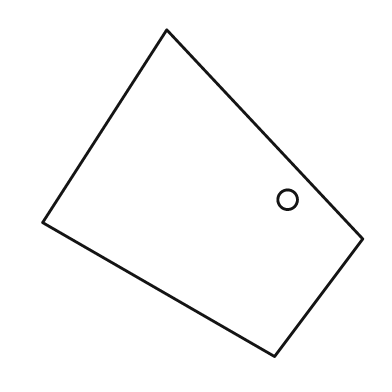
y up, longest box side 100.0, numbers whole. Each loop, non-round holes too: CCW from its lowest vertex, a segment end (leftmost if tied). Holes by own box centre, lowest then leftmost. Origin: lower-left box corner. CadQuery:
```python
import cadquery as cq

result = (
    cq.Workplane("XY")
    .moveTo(71.0, 0.0)
    .lineTo(98.0, 36.0)
    .lineTo(38.0, 100.0)
    .lineTo(0.0, 41.0)
    .close()
    .moveTo(75.0, 48.0)
    .circle(3.0)
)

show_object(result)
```